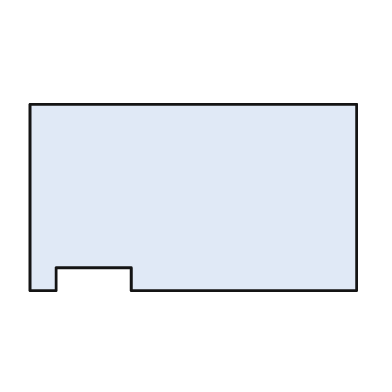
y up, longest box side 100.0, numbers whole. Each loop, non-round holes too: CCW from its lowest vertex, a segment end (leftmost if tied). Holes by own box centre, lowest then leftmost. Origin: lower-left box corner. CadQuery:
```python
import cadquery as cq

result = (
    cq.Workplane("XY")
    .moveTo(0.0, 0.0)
    .lineTo(8.0, 0.0)
    .lineTo(8.0, 7.0)
    .lineTo(31.0, 7.0)
    .lineTo(31.0, 0.0)
    .lineTo(100.0, 0.0)
    .lineTo(100.0, 57.0)
    .lineTo(0.0, 57.0)
    .close()
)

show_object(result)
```